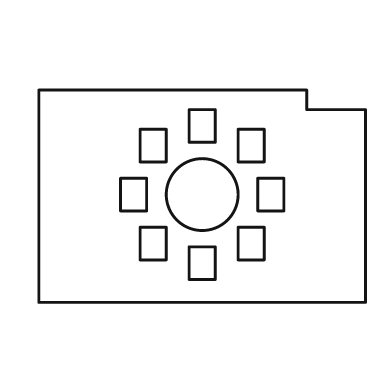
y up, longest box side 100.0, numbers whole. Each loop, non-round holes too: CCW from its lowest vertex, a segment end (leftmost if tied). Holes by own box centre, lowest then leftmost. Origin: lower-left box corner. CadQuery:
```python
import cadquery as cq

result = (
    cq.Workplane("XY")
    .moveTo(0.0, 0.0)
    .lineTo(100.0, 0.0)
    .lineTo(100.0, 59.0)
    .lineTo(82.0, 59.0)
    .lineTo(82.0, 65.0)
    .lineTo(0.0, 65.0)
    .close()
    .moveTo(46.0, 7.0)
    .lineTo(54.0, 7.0)
    .lineTo(54.0, 17.0)
    .lineTo(46.0, 17.0)
    .close()
    .moveTo(31.0, 13.0)
    .lineTo(39.0, 13.0)
    .lineTo(39.0, 23.0)
    .lineTo(31.0, 23.0)
    .close()
    .moveTo(61.0, 13.0)
    .lineTo(69.0, 13.0)
    .lineTo(69.0, 23.0)
    .lineTo(61.0, 23.0)
    .close()
    .moveTo(25.0, 28.0)
    .lineTo(33.0, 28.0)
    .lineTo(33.0, 38.0)
    .lineTo(25.0, 38.0)
    .close()
    .moveTo(50.0, 33.0)
    .circle(11.0)
    .moveTo(67.0, 28.0)
    .lineTo(75.0, 28.0)
    .lineTo(75.0, 38.0)
    .lineTo(67.0, 38.0)
    .close()
    .moveTo(31.0, 43.0)
    .lineTo(39.0, 43.0)
    .lineTo(39.0, 53.0)
    .lineTo(31.0, 53.0)
    .close()
    .moveTo(61.0, 43.0)
    .lineTo(69.0, 43.0)
    .lineTo(69.0, 53.0)
    .lineTo(61.0, 53.0)
    .close()
    .moveTo(46.0, 49.0)
    .lineTo(54.0, 49.0)
    .lineTo(54.0, 59.0)
    .lineTo(46.0, 59.0)
    .close()
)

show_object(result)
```